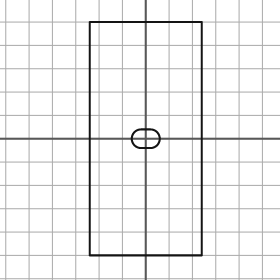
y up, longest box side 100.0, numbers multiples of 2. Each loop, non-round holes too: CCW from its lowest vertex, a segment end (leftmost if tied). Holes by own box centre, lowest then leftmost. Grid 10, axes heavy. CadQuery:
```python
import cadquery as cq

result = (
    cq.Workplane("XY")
    .moveTo(-24.0, -50.0)
    .lineTo(24.0, -50.0)
    .lineTo(24.0, 50.0)
    .lineTo(-24.0, 50.0)
    .close()
    .moveTo(-2.0, -4.0)
    .lineTo(2.0, -4.0)
    .threePointArc((6.0, 0.0), (2.0, 4.0))
    .lineTo(-2.0, 4.0)
    .threePointArc((-6.0, 0.0), (-2.0, -4.0))
    .close()
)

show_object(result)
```